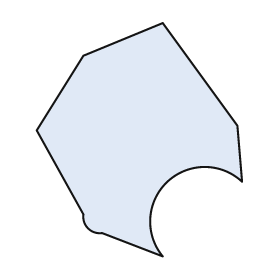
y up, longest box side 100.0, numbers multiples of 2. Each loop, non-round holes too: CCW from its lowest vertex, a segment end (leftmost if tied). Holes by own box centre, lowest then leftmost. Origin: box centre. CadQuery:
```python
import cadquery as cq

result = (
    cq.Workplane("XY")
    .moveTo(10.0, -50.0)
    .threePointArc((12.0, -18.0), (44.0, -18.0))
    .lineTo(42.0, 6.0)
    .lineTo(10.0, 50.0)
    .lineTo(-24.0, 36.0)
    .lineTo(-44.0, 4.0)
    .lineTo(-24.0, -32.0)
    .threePointArc((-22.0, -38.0), (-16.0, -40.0))
    .close()
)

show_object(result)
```